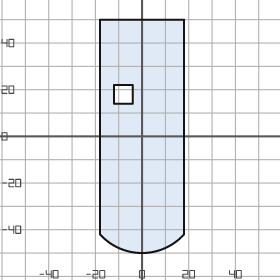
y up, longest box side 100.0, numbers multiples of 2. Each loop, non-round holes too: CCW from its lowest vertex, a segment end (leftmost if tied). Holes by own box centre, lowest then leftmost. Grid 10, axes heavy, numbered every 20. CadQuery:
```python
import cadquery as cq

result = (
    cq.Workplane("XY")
    .moveTo(-18.0, -42.0)
    .threePointArc((0.0, -50.0), (18.0, -42.0))
    .lineTo(18.0, 50.0)
    .lineTo(-18.0, 50.0)
    .close()
    .moveTo(-12.0, 14.0)
    .lineTo(-4.0, 14.0)
    .lineTo(-4.0, 22.0)
    .lineTo(-12.0, 22.0)
    .close()
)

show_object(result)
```